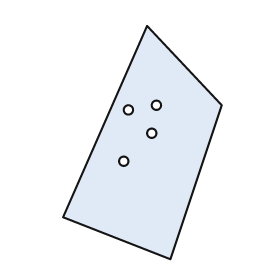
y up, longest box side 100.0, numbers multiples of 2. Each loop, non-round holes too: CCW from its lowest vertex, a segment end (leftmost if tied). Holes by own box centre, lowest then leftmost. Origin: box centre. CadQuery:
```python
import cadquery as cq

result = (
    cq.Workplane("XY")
    .moveTo(12.0, -50.0)
    .lineTo(34.0, 16.0)
    .lineTo(2.0, 50.0)
    .lineTo(-34.0, -32.0)
    .close()
    .moveTo(-8.0, -8.0)
    .circle(2.0)
    .moveTo(4.0, 4.0)
    .circle(2.0)
    .moveTo(-6.0, 14.0)
    .circle(2.0)
    .moveTo(6.0, 16.0)
    .circle(2.0)
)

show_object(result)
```